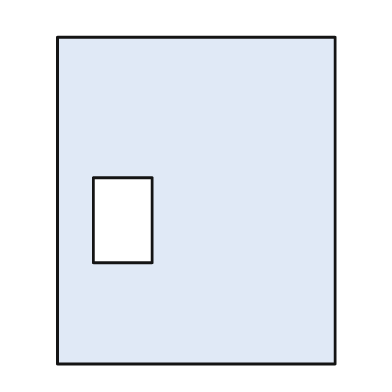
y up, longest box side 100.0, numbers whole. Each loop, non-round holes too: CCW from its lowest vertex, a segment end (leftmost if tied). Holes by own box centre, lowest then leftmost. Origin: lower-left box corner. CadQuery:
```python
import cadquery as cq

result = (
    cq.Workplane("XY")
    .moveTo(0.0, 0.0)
    .lineTo(85.0, 0.0)
    .lineTo(85.0, 100.0)
    .lineTo(0.0, 100.0)
    .close()
    .moveTo(11.0, 31.0)
    .lineTo(29.0, 31.0)
    .lineTo(29.0, 57.0)
    .lineTo(11.0, 57.0)
    .close()
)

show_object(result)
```